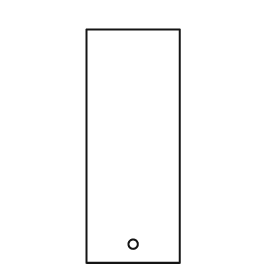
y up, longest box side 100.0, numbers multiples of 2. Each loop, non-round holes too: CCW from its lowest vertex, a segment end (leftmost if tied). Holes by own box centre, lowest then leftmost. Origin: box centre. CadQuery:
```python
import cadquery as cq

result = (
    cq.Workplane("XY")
    .moveTo(-20.0, -50.0)
    .lineTo(20.0, -50.0)
    .lineTo(20.0, 50.0)
    .lineTo(-20.0, 50.0)
    .close()
    .moveTo(0.0, -42.0)
    .circle(2.0)
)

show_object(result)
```